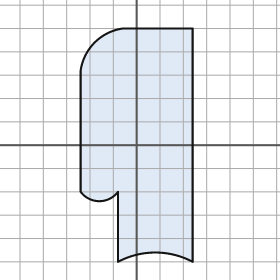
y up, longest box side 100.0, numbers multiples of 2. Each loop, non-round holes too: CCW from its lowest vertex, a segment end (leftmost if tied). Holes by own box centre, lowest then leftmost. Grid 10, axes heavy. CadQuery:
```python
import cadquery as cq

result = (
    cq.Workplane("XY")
    .moveTo(-8.0, -50.0)
    .threePointArc((8.0, -46.0), (24.0, -50.0))
    .lineTo(24.0, 50.0)
    .lineTo(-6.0, 50.0)
    .threePointArc((-18.0, 44.0), (-24.0, 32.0))
    .lineTo(-24.0, -20.0)
    .threePointArc((-16.0, -24.0), (-8.0, -20.0))
    .close()
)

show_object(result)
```